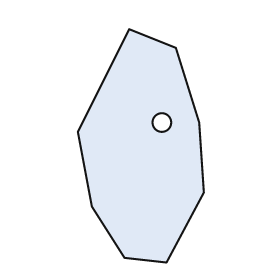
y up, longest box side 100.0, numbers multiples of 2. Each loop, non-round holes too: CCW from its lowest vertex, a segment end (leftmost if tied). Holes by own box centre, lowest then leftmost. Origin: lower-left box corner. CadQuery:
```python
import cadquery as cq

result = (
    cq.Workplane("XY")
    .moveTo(38.0, 0.0)
    .lineTo(54.0, 30.0)
    .lineTo(52.0, 60.0)
    .lineTo(42.0, 92.0)
    .lineTo(22.0, 100.0)
    .lineTo(0.0, 56.0)
    .lineTo(6.0, 24.0)
    .lineTo(20.0, 2.0)
    .close()
    .moveTo(36.0, 60.0)
    .circle(4.0)
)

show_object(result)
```